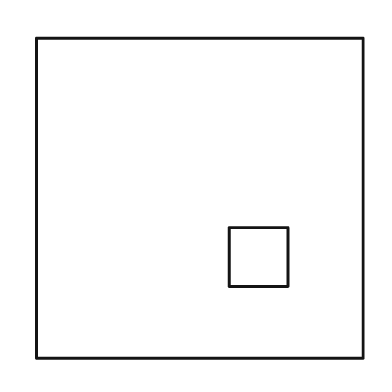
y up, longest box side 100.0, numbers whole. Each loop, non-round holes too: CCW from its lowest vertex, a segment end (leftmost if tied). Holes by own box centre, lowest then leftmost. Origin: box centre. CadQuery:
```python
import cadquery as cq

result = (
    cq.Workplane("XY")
    .moveTo(-50.0, -49.0)
    .lineTo(50.0, -49.0)
    .lineTo(50.0, 49.0)
    .lineTo(-50.0, 49.0)
    .close()
    .moveTo(9.0, -27.0)
    .lineTo(27.0, -27.0)
    .lineTo(27.0, -9.0)
    .lineTo(9.0, -9.0)
    .close()
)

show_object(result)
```